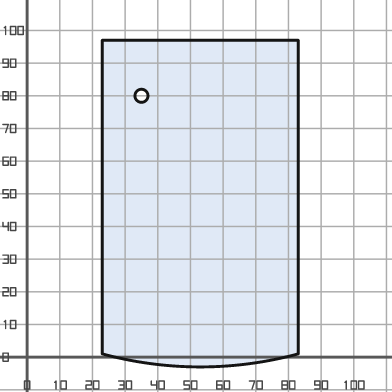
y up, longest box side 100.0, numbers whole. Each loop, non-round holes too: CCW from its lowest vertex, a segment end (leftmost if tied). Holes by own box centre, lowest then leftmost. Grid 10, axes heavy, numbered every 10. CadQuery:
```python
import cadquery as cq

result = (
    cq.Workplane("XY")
    .moveTo(23.0, 1.0)
    .threePointArc((53.0, -3.0), (83.0, 1.0))
    .lineTo(83.0, 97.0)
    .lineTo(23.0, 97.0)
    .close()
    .moveTo(35.0, 80.0)
    .circle(2.0)
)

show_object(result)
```